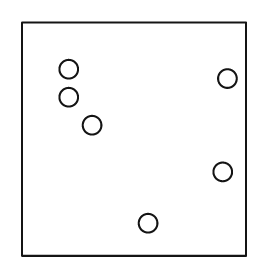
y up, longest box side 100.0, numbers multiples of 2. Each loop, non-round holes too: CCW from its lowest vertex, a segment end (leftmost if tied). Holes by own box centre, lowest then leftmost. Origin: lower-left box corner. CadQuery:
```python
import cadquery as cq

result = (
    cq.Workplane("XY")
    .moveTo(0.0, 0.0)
    .lineTo(96.0, 0.0)
    .lineTo(96.0, 100.0)
    .lineTo(0.0, 100.0)
    .close()
    .moveTo(54.0, 14.0)
    .circle(4.0)
    .moveTo(86.0, 36.0)
    .circle(4.0)
    .moveTo(30.0, 56.0)
    .circle(4.0)
    .moveTo(20.0, 68.0)
    .circle(4.0)
    .moveTo(88.0, 76.0)
    .circle(4.0)
    .moveTo(20.0, 80.0)
    .circle(4.0)
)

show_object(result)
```